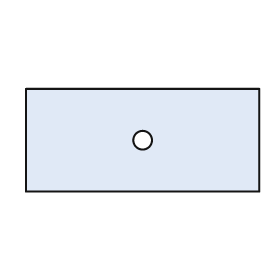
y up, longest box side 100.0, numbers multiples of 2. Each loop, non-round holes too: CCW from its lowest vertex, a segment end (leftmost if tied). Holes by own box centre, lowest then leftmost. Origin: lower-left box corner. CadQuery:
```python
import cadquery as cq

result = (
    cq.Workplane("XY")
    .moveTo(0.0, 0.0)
    .lineTo(100.0, 0.0)
    .lineTo(100.0, 44.0)
    .lineTo(0.0, 44.0)
    .close()
    .moveTo(50.0, 22.0)
    .circle(4.0)
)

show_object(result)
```